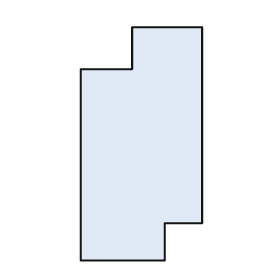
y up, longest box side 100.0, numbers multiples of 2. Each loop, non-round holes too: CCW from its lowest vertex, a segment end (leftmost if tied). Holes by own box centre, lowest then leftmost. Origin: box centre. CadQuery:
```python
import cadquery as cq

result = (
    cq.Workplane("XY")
    .moveTo(-26.0, -50.0)
    .lineTo(10.0, -50.0)
    .lineTo(10.0, -34.0)
    .lineTo(26.0, -34.0)
    .lineTo(26.0, 50.0)
    .lineTo(-4.0, 50.0)
    .lineTo(-4.0, 32.0)
    .lineTo(-26.0, 32.0)
    .close()
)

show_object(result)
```